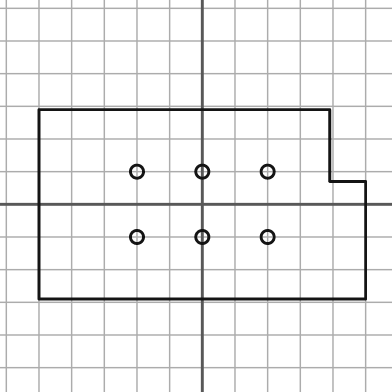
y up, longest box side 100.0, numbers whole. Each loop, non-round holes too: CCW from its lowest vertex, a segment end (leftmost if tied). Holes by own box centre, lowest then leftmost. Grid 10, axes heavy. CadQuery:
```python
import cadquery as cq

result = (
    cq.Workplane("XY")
    .moveTo(-50.0, -29.0)
    .lineTo(50.0, -29.0)
    .lineTo(50.0, 7.0)
    .lineTo(39.0, 7.0)
    .lineTo(39.0, 29.0)
    .lineTo(-50.0, 29.0)
    .close()
    .moveTo(-20.0, -10.0)
    .circle(2.0)
    .moveTo(0.0, -10.0)
    .circle(2.0)
    .moveTo(20.0, -10.0)
    .circle(2.0)
    .moveTo(-20.0, 10.0)
    .circle(2.0)
    .moveTo(0.0, 10.0)
    .circle(2.0)
    .moveTo(20.0, 10.0)
    .circle(2.0)
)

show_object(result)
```